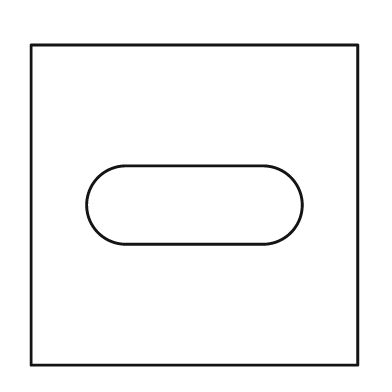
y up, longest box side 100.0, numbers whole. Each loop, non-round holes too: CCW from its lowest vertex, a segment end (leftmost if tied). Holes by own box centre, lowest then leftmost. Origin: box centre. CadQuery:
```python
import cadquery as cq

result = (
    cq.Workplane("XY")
    .moveTo(-50.0, -49.0)
    .lineTo(50.0, -49.0)
    .lineTo(50.0, 49.0)
    .lineTo(-50.0, 49.0)
    .close()
    .moveTo(-21.0, -12.0)
    .lineTo(21.0, -12.0)
    .threePointArc((33.0, 0.0), (21.0, 12.0))
    .lineTo(-21.0, 12.0)
    .threePointArc((-33.0, 0.0), (-21.0, -12.0))
    .close()
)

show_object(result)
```